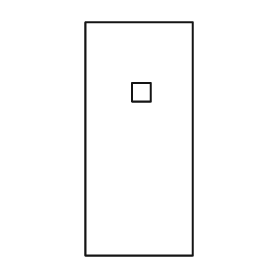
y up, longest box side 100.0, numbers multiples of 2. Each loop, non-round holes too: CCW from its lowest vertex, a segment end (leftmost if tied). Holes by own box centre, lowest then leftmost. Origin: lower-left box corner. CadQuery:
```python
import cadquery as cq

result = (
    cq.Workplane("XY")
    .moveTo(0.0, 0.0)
    .lineTo(46.0, 0.0)
    .lineTo(46.0, 100.0)
    .lineTo(0.0, 100.0)
    .close()
    .moveTo(20.0, 66.0)
    .lineTo(28.0, 66.0)
    .lineTo(28.0, 74.0)
    .lineTo(20.0, 74.0)
    .close()
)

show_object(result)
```